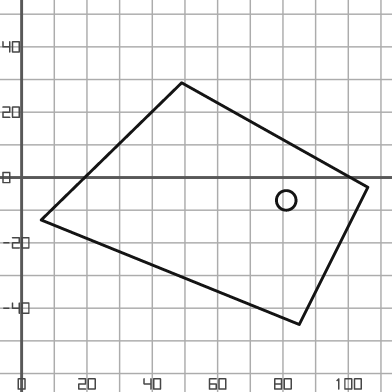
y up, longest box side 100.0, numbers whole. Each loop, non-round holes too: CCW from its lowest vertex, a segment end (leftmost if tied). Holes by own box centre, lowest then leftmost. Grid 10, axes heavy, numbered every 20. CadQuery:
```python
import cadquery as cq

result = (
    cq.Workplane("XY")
    .moveTo(85.0, -45.0)
    .lineTo(106.0, -3.0)
    .lineTo(49.0, 29.0)
    .lineTo(6.0, -13.0)
    .close()
    .moveTo(81.0, -7.0)
    .circle(3.0)
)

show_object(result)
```